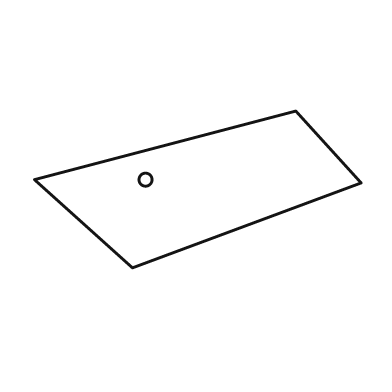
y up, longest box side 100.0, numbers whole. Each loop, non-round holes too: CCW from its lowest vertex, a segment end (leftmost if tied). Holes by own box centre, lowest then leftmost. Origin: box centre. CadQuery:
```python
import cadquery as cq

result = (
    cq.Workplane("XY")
    .moveTo(-20.0, -24.0)
    .lineTo(50.0, 2.0)
    .lineTo(30.0, 24.0)
    .lineTo(-50.0, 3.0)
    .close()
    .moveTo(-16.0, 3.0)
    .circle(2.0)
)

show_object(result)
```